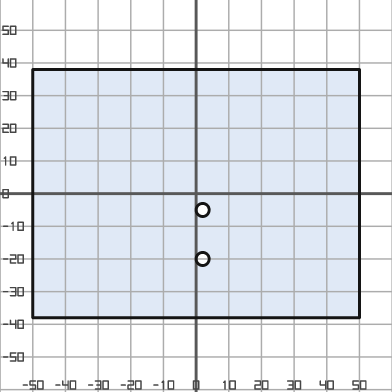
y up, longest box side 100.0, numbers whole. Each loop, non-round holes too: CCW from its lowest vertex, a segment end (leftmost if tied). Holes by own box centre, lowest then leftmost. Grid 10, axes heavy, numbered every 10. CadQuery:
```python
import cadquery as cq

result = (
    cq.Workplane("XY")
    .moveTo(-50.0, -38.0)
    .lineTo(50.0, -38.0)
    .lineTo(50.0, 38.0)
    .lineTo(-50.0, 38.0)
    .close()
    .moveTo(2.0, -20.0)
    .circle(2.0)
    .moveTo(2.0, -5.0)
    .circle(2.0)
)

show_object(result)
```